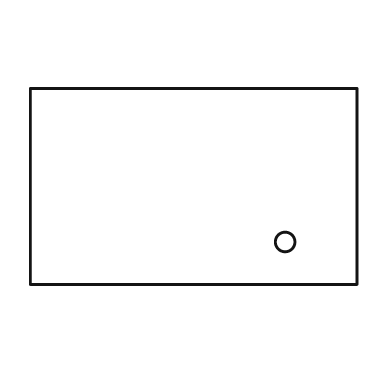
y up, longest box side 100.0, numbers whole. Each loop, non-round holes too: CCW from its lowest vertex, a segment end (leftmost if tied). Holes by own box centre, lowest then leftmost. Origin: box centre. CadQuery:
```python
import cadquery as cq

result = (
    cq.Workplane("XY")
    .moveTo(-50.0, -30.0)
    .lineTo(50.0, -30.0)
    .lineTo(50.0, 30.0)
    .lineTo(-50.0, 30.0)
    .close()
    .moveTo(28.0, -17.0)
    .circle(3.0)
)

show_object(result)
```